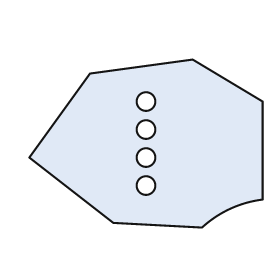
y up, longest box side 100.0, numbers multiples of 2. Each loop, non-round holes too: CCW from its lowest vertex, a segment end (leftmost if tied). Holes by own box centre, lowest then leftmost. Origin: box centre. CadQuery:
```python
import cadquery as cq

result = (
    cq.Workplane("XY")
    .moveTo(24.0, -36.0)
    .threePointArc((36.0, -28.0), (50.0, -24.0))
    .lineTo(50.0, 18.0)
    .lineTo(20.0, 36.0)
    .lineTo(-24.0, 30.0)
    .lineTo(-50.0, -6.0)
    .lineTo(-14.0, -34.0)
    .close()
    .moveTo(0.0, -18.0)
    .circle(4.0)
    .moveTo(0.0, -6.0)
    .circle(4.0)
    .moveTo(0.0, 6.0)
    .circle(4.0)
    .moveTo(0.0, 18.0)
    .circle(4.0)
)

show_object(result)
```